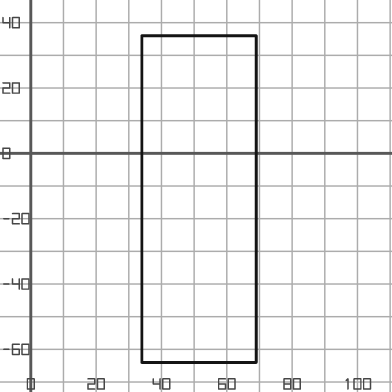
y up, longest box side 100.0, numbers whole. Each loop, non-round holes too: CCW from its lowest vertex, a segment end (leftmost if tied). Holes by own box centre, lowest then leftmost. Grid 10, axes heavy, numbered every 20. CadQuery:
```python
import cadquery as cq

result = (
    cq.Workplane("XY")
    .moveTo(34.0, -64.0)
    .lineTo(69.0, -64.0)
    .lineTo(69.0, 36.0)
    .lineTo(34.0, 36.0)
    .close()
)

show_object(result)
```